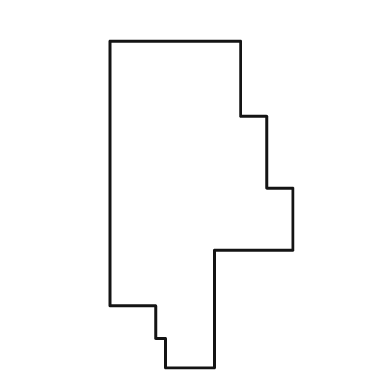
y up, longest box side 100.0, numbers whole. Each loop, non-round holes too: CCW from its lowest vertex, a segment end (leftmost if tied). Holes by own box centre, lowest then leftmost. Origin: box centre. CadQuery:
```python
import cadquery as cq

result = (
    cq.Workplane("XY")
    .moveTo(-11.0, -50.0)
    .lineTo(4.0, -50.0)
    .lineTo(4.0, -14.0)
    .lineTo(28.0, -14.0)
    .lineTo(28.0, 5.0)
    .lineTo(20.0, 5.0)
    .lineTo(20.0, 27.0)
    .lineTo(12.0, 27.0)
    .lineTo(12.0, 50.0)
    .lineTo(-28.0, 50.0)
    .lineTo(-28.0, -31.0)
    .lineTo(-14.0, -31.0)
    .lineTo(-14.0, -41.0)
    .lineTo(-11.0, -41.0)
    .close()
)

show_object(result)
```